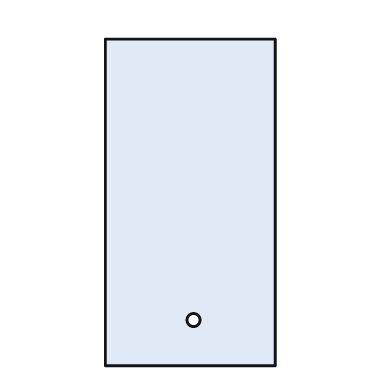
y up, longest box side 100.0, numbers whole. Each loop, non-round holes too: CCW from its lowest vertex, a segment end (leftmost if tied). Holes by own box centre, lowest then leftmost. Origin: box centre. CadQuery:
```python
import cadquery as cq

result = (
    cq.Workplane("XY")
    .moveTo(-26.0, -50.0)
    .lineTo(26.0, -50.0)
    .lineTo(26.0, 50.0)
    .lineTo(-26.0, 50.0)
    .close()
    .moveTo(1.0, -36.0)
    .circle(2.0)
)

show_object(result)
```